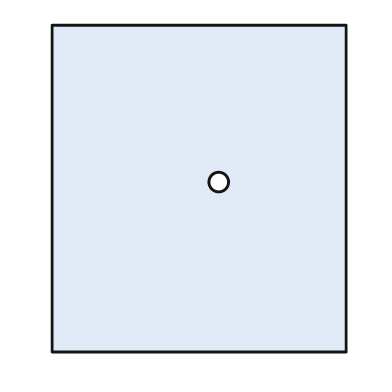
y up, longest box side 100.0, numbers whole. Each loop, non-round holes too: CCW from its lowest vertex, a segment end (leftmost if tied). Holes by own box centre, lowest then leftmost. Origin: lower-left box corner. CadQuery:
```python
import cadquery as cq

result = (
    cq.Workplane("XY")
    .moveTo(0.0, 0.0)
    .lineTo(90.0, 0.0)
    .lineTo(90.0, 100.0)
    .lineTo(0.0, 100.0)
    .close()
    .moveTo(51.0, 52.0)
    .circle(3.0)
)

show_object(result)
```